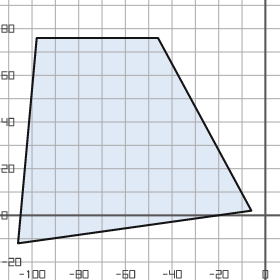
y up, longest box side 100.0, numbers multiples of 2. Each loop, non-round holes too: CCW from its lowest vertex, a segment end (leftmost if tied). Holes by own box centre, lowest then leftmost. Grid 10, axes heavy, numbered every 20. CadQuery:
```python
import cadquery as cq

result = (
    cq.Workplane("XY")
    .moveTo(-106.0, -12.0)
    .lineTo(-6.0, 2.0)
    .lineTo(-46.0, 76.0)
    .lineTo(-98.0, 76.0)
    .close()
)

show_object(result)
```